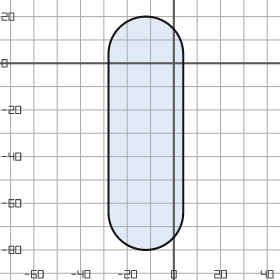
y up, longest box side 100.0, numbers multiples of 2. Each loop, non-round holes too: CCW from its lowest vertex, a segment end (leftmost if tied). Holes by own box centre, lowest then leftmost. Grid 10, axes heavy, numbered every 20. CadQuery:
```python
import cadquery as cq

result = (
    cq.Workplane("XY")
    .moveTo(-28.0, -64.0)
    .threePointArc((-12.0, -80.0), (4.0, -64.0))
    .lineTo(4.0, 4.0)
    .threePointArc((-12.0, 20.0), (-28.0, 4.0))
    .close()
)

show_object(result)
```